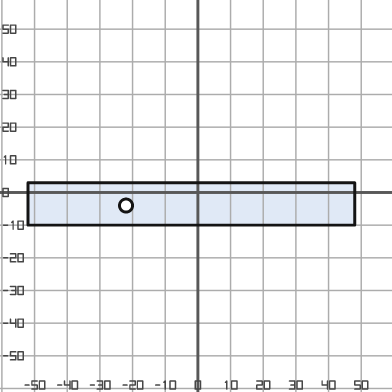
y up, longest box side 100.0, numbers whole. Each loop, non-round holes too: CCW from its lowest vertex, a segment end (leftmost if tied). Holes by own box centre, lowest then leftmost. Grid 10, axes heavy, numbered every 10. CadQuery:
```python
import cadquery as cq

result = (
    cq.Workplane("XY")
    .moveTo(-52.0, -10.0)
    .lineTo(48.0, -10.0)
    .lineTo(48.0, 3.0)
    .lineTo(-52.0, 3.0)
    .close()
    .moveTo(-22.0, -4.0)
    .circle(2.0)
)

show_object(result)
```